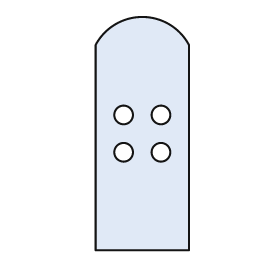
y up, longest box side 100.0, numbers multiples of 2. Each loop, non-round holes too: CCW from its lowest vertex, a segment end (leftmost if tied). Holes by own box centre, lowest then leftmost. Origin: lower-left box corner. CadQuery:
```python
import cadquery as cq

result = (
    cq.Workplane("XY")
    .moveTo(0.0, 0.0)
    .lineTo(40.0, 0.0)
    .lineTo(40.0, 88.0)
    .threePointArc((20.0, 100.0), (0.0, 88.0))
    .close()
    .moveTo(12.0, 42.0)
    .circle(4.0)
    .moveTo(28.0, 42.0)
    .circle(4.0)
    .moveTo(12.0, 58.0)
    .circle(4.0)
    .moveTo(28.0, 58.0)
    .circle(4.0)
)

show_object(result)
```